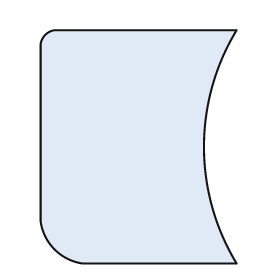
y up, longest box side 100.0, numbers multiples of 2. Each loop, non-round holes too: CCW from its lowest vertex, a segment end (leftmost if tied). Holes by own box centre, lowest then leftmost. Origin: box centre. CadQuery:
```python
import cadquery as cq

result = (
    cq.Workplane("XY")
    .moveTo(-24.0, -50.0)
    .lineTo(42.0, -50.0)
    .threePointArc((28.0, 0.0), (42.0, 50.0))
    .lineTo(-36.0, 50.0)
    .threePointArc((-40.0, 48.0), (-42.0, 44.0))
    .lineTo(-42.0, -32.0)
    .threePointArc((-36.0, -44.0), (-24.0, -50.0))
    .close()
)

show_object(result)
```